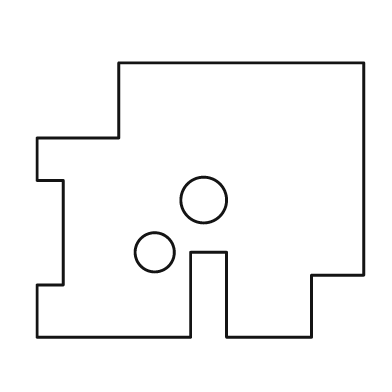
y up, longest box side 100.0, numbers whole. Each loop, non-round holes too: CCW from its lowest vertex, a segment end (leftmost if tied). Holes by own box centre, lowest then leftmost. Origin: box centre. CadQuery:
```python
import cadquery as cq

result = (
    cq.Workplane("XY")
    .moveTo(-50.0, -42.0)
    .lineTo(-3.0, -42.0)
    .lineTo(-3.0, -16.0)
    .lineTo(8.0, -16.0)
    .lineTo(8.0, -42.0)
    .lineTo(34.0, -42.0)
    .lineTo(34.0, -23.0)
    .lineTo(50.0, -23.0)
    .lineTo(50.0, 42.0)
    .lineTo(-25.0, 42.0)
    .lineTo(-25.0, 19.0)
    .lineTo(-50.0, 19.0)
    .lineTo(-50.0, 6.0)
    .lineTo(-42.0, 6.0)
    .lineTo(-42.0, -26.0)
    .lineTo(-50.0, -26.0)
    .close()
    .moveTo(-14.0, -16.0)
    .circle(6.0)
    .moveTo(1.0, 0.0)
    .circle(7.0)
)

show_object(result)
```